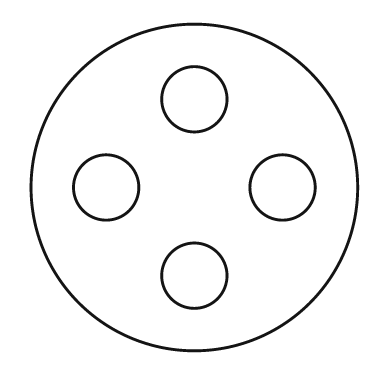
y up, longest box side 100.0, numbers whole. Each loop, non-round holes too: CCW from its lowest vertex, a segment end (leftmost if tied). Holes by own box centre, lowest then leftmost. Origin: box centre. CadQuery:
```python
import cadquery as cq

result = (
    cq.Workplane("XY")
    .moveTo(0.0, 0.0)
    .circle(50.0)
    .moveTo(0.0, -27.0)
    .circle(10.0)
    .moveTo(-27.0, 0.0)
    .circle(10.0)
    .moveTo(27.0, 0.0)
    .circle(10.0)
    .moveTo(0.0, 27.0)
    .circle(10.0)
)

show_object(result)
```